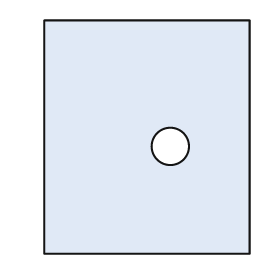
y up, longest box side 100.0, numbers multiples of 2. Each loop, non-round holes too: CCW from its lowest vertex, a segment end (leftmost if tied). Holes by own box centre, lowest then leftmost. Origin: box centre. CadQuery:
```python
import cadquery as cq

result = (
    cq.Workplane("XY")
    .moveTo(-44.0, -50.0)
    .lineTo(44.0, -50.0)
    .lineTo(44.0, 50.0)
    .lineTo(-44.0, 50.0)
    .close()
    .moveTo(10.0, -4.0)
    .circle(8.0)
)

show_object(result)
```